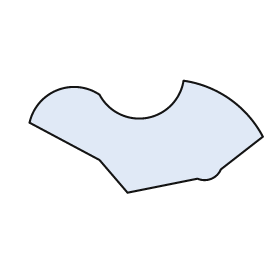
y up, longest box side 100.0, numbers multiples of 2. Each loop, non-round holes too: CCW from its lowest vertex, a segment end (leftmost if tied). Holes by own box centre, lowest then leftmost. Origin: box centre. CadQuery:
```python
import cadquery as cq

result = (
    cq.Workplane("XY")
    .moveTo(-8.0, -24.0)
    .lineTo(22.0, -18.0)
    .threePointArc((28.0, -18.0), (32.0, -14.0))
    .lineTo(50.0, 0.0)
    .threePointArc((36.0, 16.0), (16.0, 24.0))
    .threePointArc((0.0, 8.0), (-20.0, 18.0))
    .threePointArc((-38.0, 20.0), (-50.0, 6.0))
    .lineTo(-20.0, -10.0)
    .close()
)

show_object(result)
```